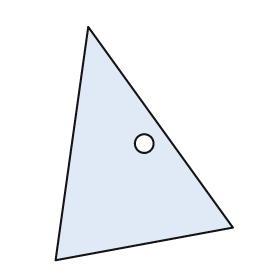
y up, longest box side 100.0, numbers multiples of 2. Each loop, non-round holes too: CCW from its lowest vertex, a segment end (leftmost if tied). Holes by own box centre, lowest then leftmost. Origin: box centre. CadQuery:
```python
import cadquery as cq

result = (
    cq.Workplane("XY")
    .moveTo(-38.0, -50.0)
    .lineTo(38.0, -36.0)
    .lineTo(-24.0, 50.0)
    .close()
    .moveTo(0.0, 0.0)
    .circle(4.0)
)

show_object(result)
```